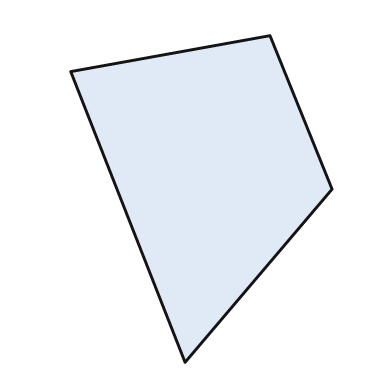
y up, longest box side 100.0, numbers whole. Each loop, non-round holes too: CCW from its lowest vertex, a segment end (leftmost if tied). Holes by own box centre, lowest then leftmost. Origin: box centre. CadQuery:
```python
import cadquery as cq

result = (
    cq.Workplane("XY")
    .moveTo(-5.0, -50.0)
    .lineTo(40.0, 3.0)
    .lineTo(21.0, 50.0)
    .lineTo(-40.0, 39.0)
    .close()
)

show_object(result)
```